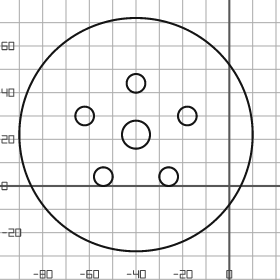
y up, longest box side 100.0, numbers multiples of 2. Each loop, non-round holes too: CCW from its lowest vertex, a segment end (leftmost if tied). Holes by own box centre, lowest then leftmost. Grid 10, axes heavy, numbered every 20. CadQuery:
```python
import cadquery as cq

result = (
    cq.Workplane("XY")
    .moveTo(-40.0, 22.0)
    .circle(50.0)
    .moveTo(-54.0, 4.0)
    .circle(4.0)
    .moveTo(-26.0, 4.0)
    .circle(4.0)
    .moveTo(-40.0, 22.0)
    .circle(6.0)
    .moveTo(-62.0, 30.0)
    .circle(4.0)
    .moveTo(-18.0, 30.0)
    .circle(4.0)
    .moveTo(-40.0, 44.0)
    .circle(4.0)
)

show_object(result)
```